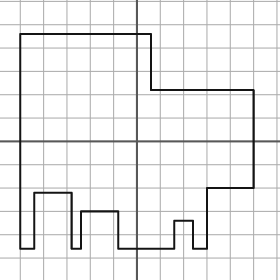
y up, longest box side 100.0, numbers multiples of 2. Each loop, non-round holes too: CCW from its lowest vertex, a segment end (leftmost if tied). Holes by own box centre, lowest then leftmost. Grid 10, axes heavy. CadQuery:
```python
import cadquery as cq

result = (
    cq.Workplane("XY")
    .moveTo(-50.0, -46.0)
    .lineTo(-44.0, -46.0)
    .lineTo(-44.0, -22.0)
    .lineTo(-28.0, -22.0)
    .lineTo(-28.0, -46.0)
    .lineTo(-24.0, -46.0)
    .lineTo(-24.0, -30.0)
    .lineTo(-8.0, -30.0)
    .lineTo(-8.0, -46.0)
    .lineTo(16.0, -46.0)
    .lineTo(16.0, -34.0)
    .lineTo(24.0, -34.0)
    .lineTo(24.0, -46.0)
    .lineTo(30.0, -46.0)
    .lineTo(30.0, -20.0)
    .lineTo(50.0, -20.0)
    .lineTo(50.0, 22.0)
    .lineTo(6.0, 22.0)
    .lineTo(6.0, 46.0)
    .lineTo(-50.0, 46.0)
    .close()
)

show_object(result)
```